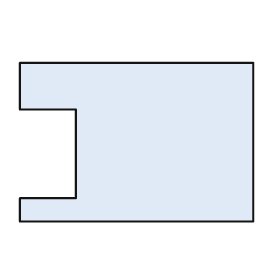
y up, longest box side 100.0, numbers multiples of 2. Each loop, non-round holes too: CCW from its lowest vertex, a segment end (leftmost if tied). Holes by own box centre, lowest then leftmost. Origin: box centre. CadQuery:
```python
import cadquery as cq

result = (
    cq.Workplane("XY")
    .moveTo(-50.0, -34.0)
    .lineTo(50.0, -34.0)
    .lineTo(50.0, 34.0)
    .lineTo(-50.0, 34.0)
    .lineTo(-50.0, 14.0)
    .lineTo(-26.0, 14.0)
    .lineTo(-26.0, -24.0)
    .lineTo(-50.0, -24.0)
    .close()
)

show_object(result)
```